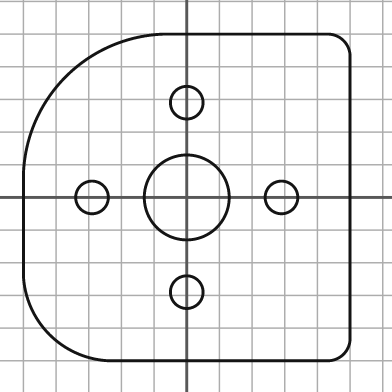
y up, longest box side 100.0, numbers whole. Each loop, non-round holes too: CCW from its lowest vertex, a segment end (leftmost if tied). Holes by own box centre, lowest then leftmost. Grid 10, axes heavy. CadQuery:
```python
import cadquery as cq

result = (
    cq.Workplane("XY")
    .moveTo(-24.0, -50.0)
    .lineTo(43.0, -50.0)
    .threePointArc((48.0, -48.0), (50.0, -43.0))
    .lineTo(50.0, 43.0)
    .threePointArc((48.0, 48.0), (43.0, 50.0))
    .lineTo(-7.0, 50.0)
    .threePointArc((-37.0, 37.0), (-50.0, 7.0))
    .lineTo(-50.0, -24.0)
    .threePointArc((-42.0, -42.0), (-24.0, -50.0))
    .close()
    .moveTo(0.0, -29.0)
    .circle(5.0)
    .moveTo(-29.0, 0.0)
    .circle(5.0)
    .moveTo(0.0, 0.0)
    .circle(13.0)
    .moveTo(29.0, 0.0)
    .circle(5.0)
    .moveTo(0.0, 29.0)
    .circle(5.0)
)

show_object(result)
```